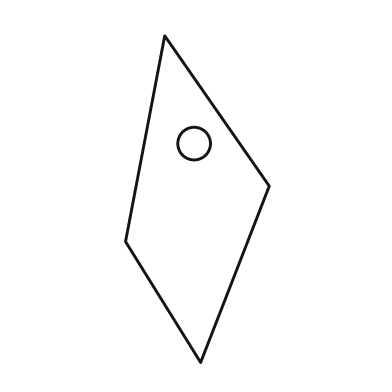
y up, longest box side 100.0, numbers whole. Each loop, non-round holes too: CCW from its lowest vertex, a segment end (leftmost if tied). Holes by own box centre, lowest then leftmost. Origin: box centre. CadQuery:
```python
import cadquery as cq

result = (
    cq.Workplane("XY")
    .moveTo(1.0, -50.0)
    .lineTo(22.0, 4.0)
    .lineTo(-10.0, 50.0)
    .lineTo(-22.0, -13.0)
    .close()
    .moveTo(-1.0, 17.0)
    .circle(5.0)
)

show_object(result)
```